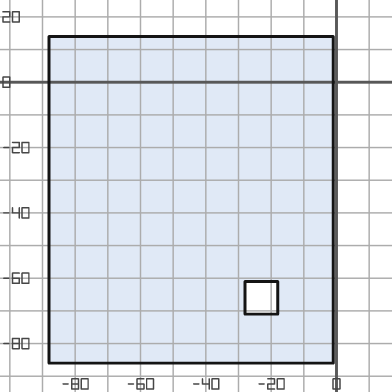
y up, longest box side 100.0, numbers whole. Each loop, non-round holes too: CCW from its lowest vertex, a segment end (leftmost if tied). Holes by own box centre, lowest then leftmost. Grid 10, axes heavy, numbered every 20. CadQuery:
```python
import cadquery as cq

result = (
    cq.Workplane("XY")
    .moveTo(-88.0, -86.0)
    .lineTo(-1.0, -86.0)
    .lineTo(-1.0, 14.0)
    .lineTo(-88.0, 14.0)
    .close()
    .moveTo(-28.0, -71.0)
    .lineTo(-18.0, -71.0)
    .lineTo(-18.0, -61.0)
    .lineTo(-28.0, -61.0)
    .close()
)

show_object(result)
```